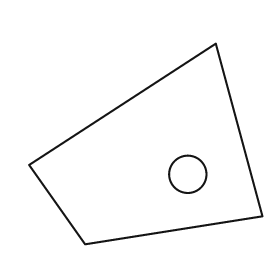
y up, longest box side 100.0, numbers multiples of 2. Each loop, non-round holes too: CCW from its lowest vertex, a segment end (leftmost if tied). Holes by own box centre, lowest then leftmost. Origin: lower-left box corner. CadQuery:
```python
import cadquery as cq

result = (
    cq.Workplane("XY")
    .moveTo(24.0, 0.0)
    .lineTo(100.0, 12.0)
    .lineTo(80.0, 86.0)
    .lineTo(0.0, 34.0)
    .close()
    .moveTo(68.0, 30.0)
    .circle(8.0)
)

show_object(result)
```